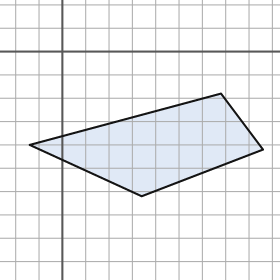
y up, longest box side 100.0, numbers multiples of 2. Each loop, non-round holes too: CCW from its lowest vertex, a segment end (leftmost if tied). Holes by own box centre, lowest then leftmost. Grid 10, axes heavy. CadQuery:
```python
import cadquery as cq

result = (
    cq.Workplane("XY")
    .moveTo(34.0, -62.0)
    .lineTo(86.0, -42.0)
    .lineTo(68.0, -18.0)
    .lineTo(-14.0, -40.0)
    .close()
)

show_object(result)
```